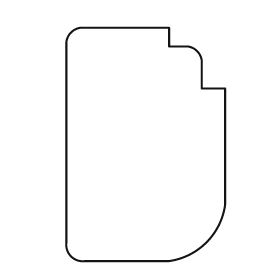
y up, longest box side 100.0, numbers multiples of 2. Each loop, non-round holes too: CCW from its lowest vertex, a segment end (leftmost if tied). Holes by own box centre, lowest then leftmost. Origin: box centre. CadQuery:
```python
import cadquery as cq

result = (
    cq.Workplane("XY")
    .moveTo(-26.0, -50.0)
    .lineTo(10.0, -50.0)
    .threePointArc((26.0, -42.0), (34.0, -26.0))
    .lineTo(34.0, 24.0)
    .lineTo(24.0, 24.0)
    .lineTo(24.0, 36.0)
    .threePointArc((22.0, 40.0), (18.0, 42.0))
    .lineTo(10.0, 42.0)
    .lineTo(10.0, 50.0)
    .lineTo(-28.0, 50.0)
    .threePointArc((-32.0, 48.0), (-34.0, 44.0))
    .lineTo(-34.0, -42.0)
    .threePointArc((-32.0, -48.0), (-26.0, -50.0))
    .close()
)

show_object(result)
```